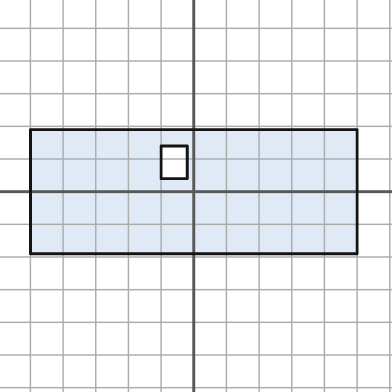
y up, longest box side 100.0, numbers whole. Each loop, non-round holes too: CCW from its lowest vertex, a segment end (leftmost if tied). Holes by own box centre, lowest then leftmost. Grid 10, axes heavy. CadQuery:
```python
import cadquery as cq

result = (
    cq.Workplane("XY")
    .moveTo(-50.0, -19.0)
    .lineTo(50.0, -19.0)
    .lineTo(50.0, 19.0)
    .lineTo(-50.0, 19.0)
    .close()
    .moveTo(-10.0, 4.0)
    .lineTo(-2.0, 4.0)
    .lineTo(-2.0, 14.0)
    .lineTo(-10.0, 14.0)
    .close()
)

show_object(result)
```